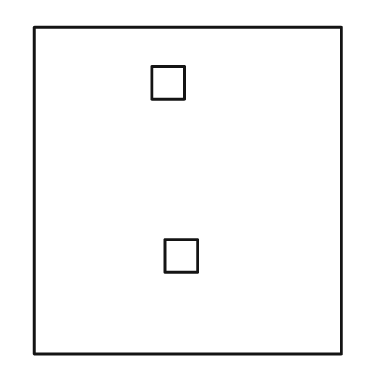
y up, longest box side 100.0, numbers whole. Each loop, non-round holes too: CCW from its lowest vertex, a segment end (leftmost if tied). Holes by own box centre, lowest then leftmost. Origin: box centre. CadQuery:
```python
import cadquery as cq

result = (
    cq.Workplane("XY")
    .moveTo(-47.0, -50.0)
    .lineTo(47.0, -50.0)
    .lineTo(47.0, 50.0)
    .lineTo(-47.0, 50.0)
    .close()
    .moveTo(-7.0, -25.0)
    .lineTo(3.0, -25.0)
    .lineTo(3.0, -15.0)
    .lineTo(-7.0, -15.0)
    .close()
    .moveTo(-11.0, 28.0)
    .lineTo(-1.0, 28.0)
    .lineTo(-1.0, 38.0)
    .lineTo(-11.0, 38.0)
    .close()
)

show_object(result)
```